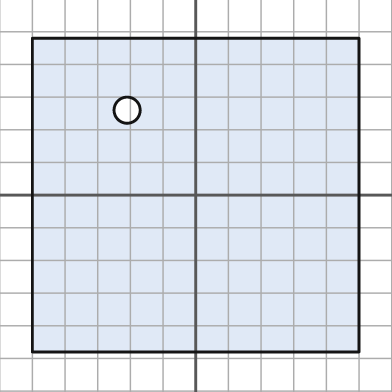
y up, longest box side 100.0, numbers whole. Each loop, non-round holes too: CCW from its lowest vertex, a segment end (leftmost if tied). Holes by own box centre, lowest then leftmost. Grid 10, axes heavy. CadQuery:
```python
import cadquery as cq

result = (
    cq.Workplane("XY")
    .moveTo(-50.0, -48.0)
    .lineTo(50.0, -48.0)
    .lineTo(50.0, 48.0)
    .lineTo(-50.0, 48.0)
    .close()
    .moveTo(-21.0, 26.0)
    .circle(4.0)
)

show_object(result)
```